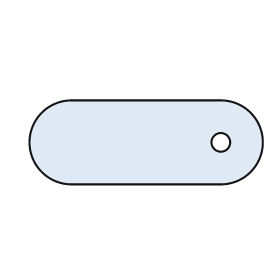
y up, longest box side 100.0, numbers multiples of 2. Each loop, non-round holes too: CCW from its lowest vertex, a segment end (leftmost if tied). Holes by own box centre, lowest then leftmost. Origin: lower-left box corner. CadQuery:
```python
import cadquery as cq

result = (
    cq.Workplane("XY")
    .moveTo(18.0, 0.0)
    .lineTo(82.0, 0.0)
    .threePointArc((100.0, 18.0), (82.0, 36.0))
    .lineTo(18.0, 36.0)
    .threePointArc((0.0, 18.0), (18.0, 0.0))
    .close()
    .moveTo(82.0, 18.0)
    .circle(4.0)
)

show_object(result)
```